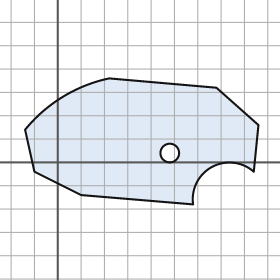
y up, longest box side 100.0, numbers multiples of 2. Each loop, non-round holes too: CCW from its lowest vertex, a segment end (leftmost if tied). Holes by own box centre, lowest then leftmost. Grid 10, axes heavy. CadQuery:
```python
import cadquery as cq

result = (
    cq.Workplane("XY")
    .moveTo(58.0, -18.0)
    .threePointArc((66.0, -2.0), (84.0, -4.0))
    .lineTo(86.0, 16.0)
    .lineTo(68.0, 32.0)
    .lineTo(22.0, 36.0)
    .threePointArc((2.0, 28.0), (-14.0, 14.0))
    .lineTo(-10.0, -4.0)
    .lineTo(10.0, -14.0)
    .close()
    .moveTo(48.0, 4.0)
    .circle(4.0)
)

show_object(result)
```